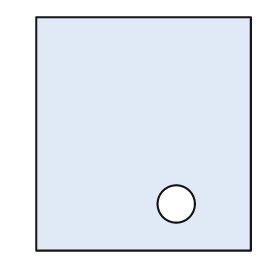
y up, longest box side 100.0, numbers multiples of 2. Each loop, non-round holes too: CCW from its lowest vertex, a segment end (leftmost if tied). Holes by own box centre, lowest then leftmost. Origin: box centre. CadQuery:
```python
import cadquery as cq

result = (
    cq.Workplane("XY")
    .moveTo(-46.0, -50.0)
    .lineTo(46.0, -50.0)
    .lineTo(46.0, 50.0)
    .lineTo(-46.0, 50.0)
    .close()
    .moveTo(14.0, -30.0)
    .circle(8.0)
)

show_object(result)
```